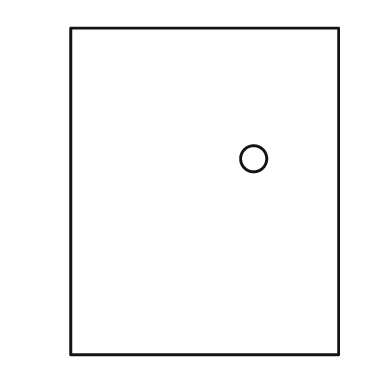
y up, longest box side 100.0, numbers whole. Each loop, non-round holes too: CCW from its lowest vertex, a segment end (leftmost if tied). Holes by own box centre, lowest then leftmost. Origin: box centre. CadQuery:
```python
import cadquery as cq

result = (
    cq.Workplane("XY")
    .moveTo(-41.0, -50.0)
    .lineTo(41.0, -50.0)
    .lineTo(41.0, 50.0)
    .lineTo(-41.0, 50.0)
    .close()
    .moveTo(15.0, 10.0)
    .circle(4.0)
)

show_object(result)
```